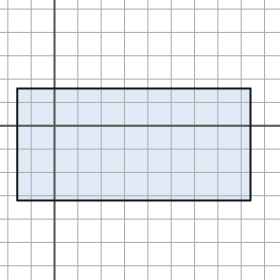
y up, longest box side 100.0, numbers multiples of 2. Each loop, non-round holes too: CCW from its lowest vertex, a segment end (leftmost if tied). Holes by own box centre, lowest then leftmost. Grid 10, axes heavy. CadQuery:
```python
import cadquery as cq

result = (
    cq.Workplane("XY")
    .moveTo(-16.0, -32.0)
    .lineTo(84.0, -32.0)
    .lineTo(84.0, 16.0)
    .lineTo(-16.0, 16.0)
    .close()
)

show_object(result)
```